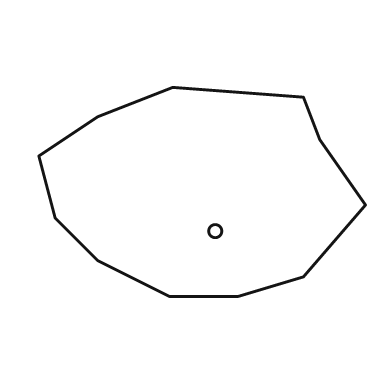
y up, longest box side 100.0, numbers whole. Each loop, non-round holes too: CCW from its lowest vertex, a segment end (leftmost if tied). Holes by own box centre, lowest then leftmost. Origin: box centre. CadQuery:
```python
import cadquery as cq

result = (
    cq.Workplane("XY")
    .moveTo(-10.0, -32.0)
    .lineTo(11.0, -32.0)
    .lineTo(31.0, -26.0)
    .lineTo(50.0, -4.0)
    .lineTo(36.0, 16.0)
    .lineTo(31.0, 29.0)
    .lineTo(-9.0, 32.0)
    .lineTo(-32.0, 23.0)
    .lineTo(-50.0, 11.0)
    .lineTo(-45.0, -8.0)
    .lineTo(-32.0, -21.0)
    .close()
    .moveTo(4.0, -12.0)
    .circle(2.0)
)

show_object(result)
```